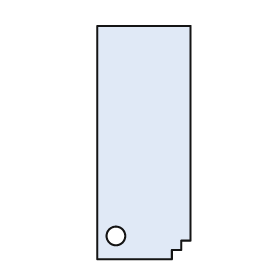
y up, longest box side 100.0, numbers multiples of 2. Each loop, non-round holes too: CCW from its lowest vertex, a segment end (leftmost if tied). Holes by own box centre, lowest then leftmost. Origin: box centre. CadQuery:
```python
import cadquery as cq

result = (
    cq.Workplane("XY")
    .moveTo(-20.0, -50.0)
    .lineTo(12.0, -50.0)
    .lineTo(12.0, -46.0)
    .lineTo(16.0, -46.0)
    .lineTo(16.0, -42.0)
    .lineTo(20.0, -42.0)
    .lineTo(20.0, 50.0)
    .lineTo(-20.0, 50.0)
    .close()
    .moveTo(-12.0, -40.0)
    .circle(4.0)
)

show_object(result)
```